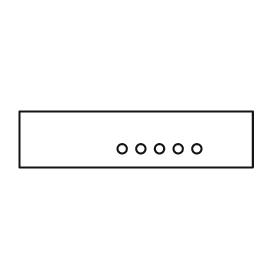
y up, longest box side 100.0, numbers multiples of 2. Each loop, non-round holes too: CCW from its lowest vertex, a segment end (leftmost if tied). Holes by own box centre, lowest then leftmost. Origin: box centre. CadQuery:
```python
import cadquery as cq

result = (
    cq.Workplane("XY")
    .moveTo(-50.0, -12.0)
    .lineTo(50.0, -12.0)
    .lineTo(50.0, 12.0)
    .lineTo(-50.0, 12.0)
    .close()
    .moveTo(-6.0, -4.0)
    .circle(2.0)
    .moveTo(2.0, -4.0)
    .circle(2.0)
    .moveTo(10.0, -4.0)
    .circle(2.0)
    .moveTo(18.0, -4.0)
    .circle(2.0)
    .moveTo(26.0, -4.0)
    .circle(2.0)
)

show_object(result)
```